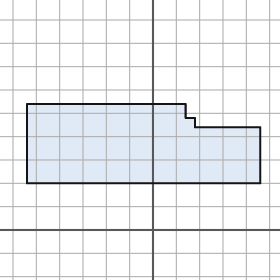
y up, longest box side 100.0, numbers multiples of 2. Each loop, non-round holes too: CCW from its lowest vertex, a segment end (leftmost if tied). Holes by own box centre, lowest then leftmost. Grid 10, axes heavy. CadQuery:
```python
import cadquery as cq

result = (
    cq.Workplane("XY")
    .moveTo(-54.0, 20.0)
    .lineTo(46.0, 20.0)
    .lineTo(46.0, 44.0)
    .lineTo(18.0, 44.0)
    .lineTo(18.0, 48.0)
    .lineTo(14.0, 48.0)
    .lineTo(14.0, 54.0)
    .lineTo(-54.0, 54.0)
    .close()
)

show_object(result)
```